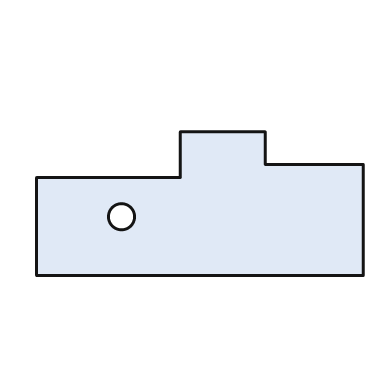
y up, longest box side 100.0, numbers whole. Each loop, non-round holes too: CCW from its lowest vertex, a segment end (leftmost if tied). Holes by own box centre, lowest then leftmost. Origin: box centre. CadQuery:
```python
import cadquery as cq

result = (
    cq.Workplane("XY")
    .moveTo(-50.0, -22.0)
    .lineTo(50.0, -22.0)
    .lineTo(50.0, 12.0)
    .lineTo(20.0, 12.0)
    .lineTo(20.0, 22.0)
    .lineTo(-6.0, 22.0)
    .lineTo(-6.0, 8.0)
    .lineTo(-50.0, 8.0)
    .close()
    .moveTo(-24.0, -4.0)
    .circle(4.0)
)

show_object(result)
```